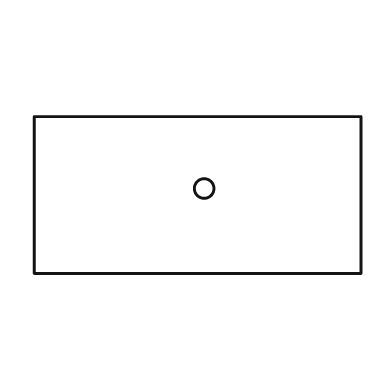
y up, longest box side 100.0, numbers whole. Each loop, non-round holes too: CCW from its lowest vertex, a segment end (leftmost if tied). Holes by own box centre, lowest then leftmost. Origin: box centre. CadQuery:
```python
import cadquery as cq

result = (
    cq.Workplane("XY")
    .moveTo(-50.0, -24.0)
    .lineTo(50.0, -24.0)
    .lineTo(50.0, 24.0)
    .lineTo(-50.0, 24.0)
    .close()
    .moveTo(2.0, 2.0)
    .circle(3.0)
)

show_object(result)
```